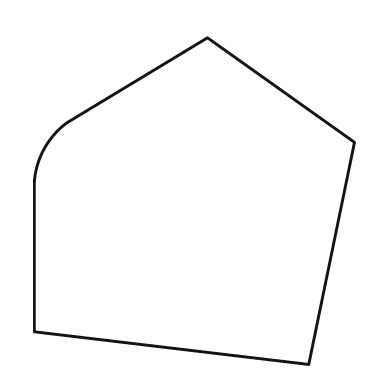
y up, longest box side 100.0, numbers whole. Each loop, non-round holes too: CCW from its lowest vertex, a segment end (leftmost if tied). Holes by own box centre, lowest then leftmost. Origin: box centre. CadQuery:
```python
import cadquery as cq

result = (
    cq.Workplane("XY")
    .moveTo(35.0, -50.0)
    .lineTo(49.0, 18.0)
    .lineTo(4.0, 50.0)
    .lineTo(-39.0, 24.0)
    .threePointArc((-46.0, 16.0), (-49.0, 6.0))
    .lineTo(-49.0, -40.0)
    .close()
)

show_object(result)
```